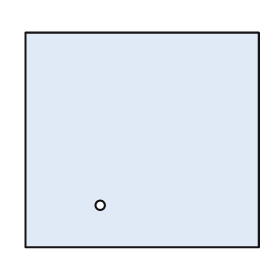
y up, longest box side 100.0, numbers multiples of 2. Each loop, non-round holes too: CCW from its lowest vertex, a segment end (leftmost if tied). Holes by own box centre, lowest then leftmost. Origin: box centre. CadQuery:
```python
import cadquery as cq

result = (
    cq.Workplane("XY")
    .moveTo(-50.0, -46.0)
    .lineTo(50.0, -46.0)
    .lineTo(50.0, 46.0)
    .lineTo(-50.0, 46.0)
    .close()
    .moveTo(-18.0, -28.0)
    .circle(2.0)
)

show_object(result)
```